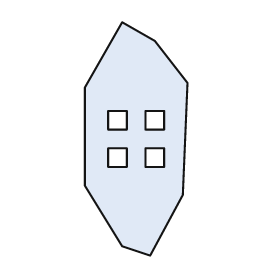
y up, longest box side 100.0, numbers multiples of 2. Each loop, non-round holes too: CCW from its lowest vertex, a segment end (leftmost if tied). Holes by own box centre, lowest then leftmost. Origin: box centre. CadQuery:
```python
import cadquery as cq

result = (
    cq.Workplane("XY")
    .moveTo(6.0, -50.0)
    .lineTo(20.0, -24.0)
    .lineTo(22.0, 24.0)
    .lineTo(8.0, 42.0)
    .lineTo(-6.0, 50.0)
    .lineTo(-22.0, 22.0)
    .lineTo(-22.0, -20.0)
    .lineTo(-6.0, -46.0)
    .close()
    .moveTo(-12.0, -12.0)
    .lineTo(-4.0, -12.0)
    .lineTo(-4.0, -4.0)
    .lineTo(-12.0, -4.0)
    .close()
    .moveTo(4.0, -12.0)
    .lineTo(12.0, -12.0)
    .lineTo(12.0, -4.0)
    .lineTo(4.0, -4.0)
    .close()
    .moveTo(-12.0, 4.0)
    .lineTo(-4.0, 4.0)
    .lineTo(-4.0, 12.0)
    .lineTo(-12.0, 12.0)
    .close()
    .moveTo(4.0, 4.0)
    .lineTo(12.0, 4.0)
    .lineTo(12.0, 12.0)
    .lineTo(4.0, 12.0)
    .close()
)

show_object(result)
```